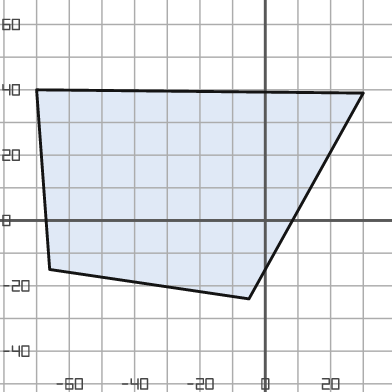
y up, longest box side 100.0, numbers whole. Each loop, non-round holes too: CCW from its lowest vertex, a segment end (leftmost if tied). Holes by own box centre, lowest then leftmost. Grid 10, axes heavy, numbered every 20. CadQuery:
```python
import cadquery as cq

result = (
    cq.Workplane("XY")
    .moveTo(-5.0, -24.0)
    .lineTo(30.0, 39.0)
    .lineTo(-70.0, 40.0)
    .lineTo(-66.0, -15.0)
    .close()
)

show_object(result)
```